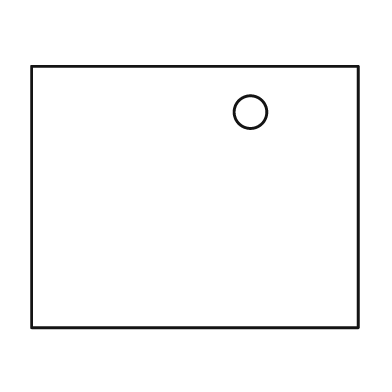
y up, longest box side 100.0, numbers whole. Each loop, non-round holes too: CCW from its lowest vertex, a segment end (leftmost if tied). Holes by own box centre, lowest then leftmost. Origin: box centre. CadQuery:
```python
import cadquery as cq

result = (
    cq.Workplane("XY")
    .moveTo(-50.0, -40.0)
    .lineTo(50.0, -40.0)
    .lineTo(50.0, 40.0)
    .lineTo(-50.0, 40.0)
    .close()
    .moveTo(17.0, 26.0)
    .circle(5.0)
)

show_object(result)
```